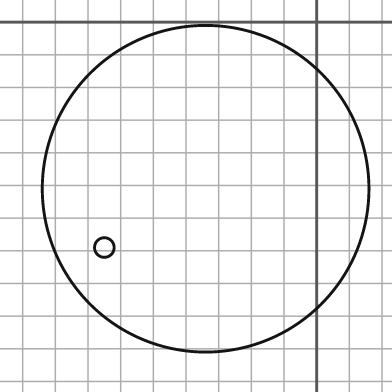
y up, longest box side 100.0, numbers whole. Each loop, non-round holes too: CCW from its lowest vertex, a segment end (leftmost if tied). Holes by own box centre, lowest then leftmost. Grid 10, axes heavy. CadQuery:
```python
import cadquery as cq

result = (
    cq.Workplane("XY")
    .moveTo(-34.0, -51.0)
    .circle(50.0)
    .moveTo(-65.0, -69.0)
    .circle(3.0)
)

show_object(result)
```